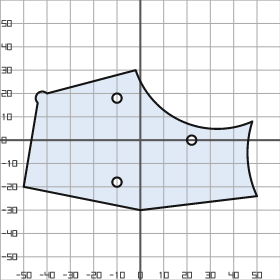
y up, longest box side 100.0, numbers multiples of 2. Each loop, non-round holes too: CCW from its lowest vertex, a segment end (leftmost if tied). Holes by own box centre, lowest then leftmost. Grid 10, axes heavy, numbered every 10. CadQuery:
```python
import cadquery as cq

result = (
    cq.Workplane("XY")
    .moveTo(0.0, -30.0)
    .lineTo(50.0, -24.0)
    .threePointArc((46.0, -8.0), (48.0, 8.0))
    .threePointArc((18.0, 8.0), (-2.0, 30.0))
    .lineTo(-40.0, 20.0)
    .threePointArc((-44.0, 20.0), (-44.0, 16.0))
    .lineTo(-50.0, -20.0)
    .close()
    .moveTo(-10.0, -18.0)
    .circle(2.0)
    .moveTo(22.0, 0.0)
    .circle(2.0)
    .moveTo(-10.0, 18.0)
    .circle(2.0)
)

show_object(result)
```